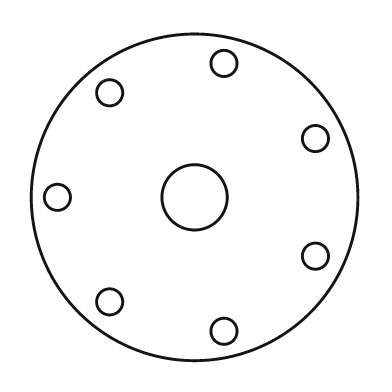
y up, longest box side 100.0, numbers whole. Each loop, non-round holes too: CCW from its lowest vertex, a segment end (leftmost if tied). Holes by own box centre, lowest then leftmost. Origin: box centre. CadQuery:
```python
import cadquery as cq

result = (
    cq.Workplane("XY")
    .moveTo(0.0, 0.0)
    .circle(50.0)
    .moveTo(9.0, -41.0)
    .circle(4.0)
    .moveTo(-26.0, -32.0)
    .circle(4.0)
    .moveTo(37.0, -18.0)
    .circle(4.0)
    .moveTo(-42.0, 0.0)
    .circle(4.0)
    .moveTo(0.0, 0.0)
    .circle(10.0)
    .moveTo(37.0, 18.0)
    .circle(4.0)
    .moveTo(-26.0, 32.0)
    .circle(4.0)
    .moveTo(9.0, 41.0)
    .circle(4.0)
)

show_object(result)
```